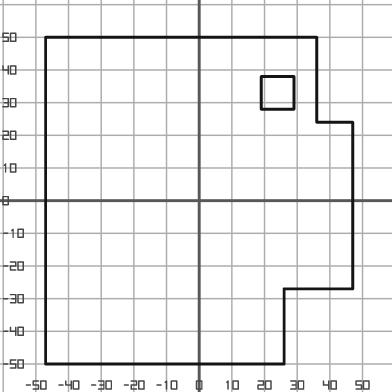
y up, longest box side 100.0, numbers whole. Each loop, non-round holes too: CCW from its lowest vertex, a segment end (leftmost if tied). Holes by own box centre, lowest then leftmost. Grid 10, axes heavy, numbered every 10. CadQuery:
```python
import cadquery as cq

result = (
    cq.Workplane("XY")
    .moveTo(-47.0, -50.0)
    .lineTo(26.0, -50.0)
    .lineTo(26.0, -27.0)
    .lineTo(47.0, -27.0)
    .lineTo(47.0, 24.0)
    .lineTo(36.0, 24.0)
    .lineTo(36.0, 50.0)
    .lineTo(-47.0, 50.0)
    .close()
    .moveTo(19.0, 28.0)
    .lineTo(29.0, 28.0)
    .lineTo(29.0, 38.0)
    .lineTo(19.0, 38.0)
    .close()
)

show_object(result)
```